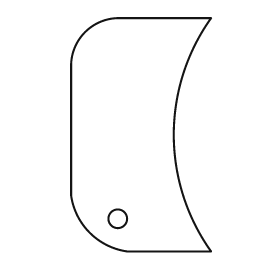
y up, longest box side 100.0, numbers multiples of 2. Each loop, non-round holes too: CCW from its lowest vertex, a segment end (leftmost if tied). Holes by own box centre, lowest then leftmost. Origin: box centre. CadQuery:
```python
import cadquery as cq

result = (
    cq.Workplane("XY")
    .moveTo(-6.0, -50.0)
    .lineTo(30.0, -50.0)
    .threePointArc((14.0, 0.0), (30.0, 50.0))
    .lineTo(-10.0, 50.0)
    .threePointArc((-24.0, 44.0), (-30.0, 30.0))
    .lineTo(-30.0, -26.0)
    .threePointArc((-22.0, -42.0), (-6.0, -50.0))
    .close()
    .moveTo(-10.0, -36.0)
    .circle(4.0)
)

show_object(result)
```